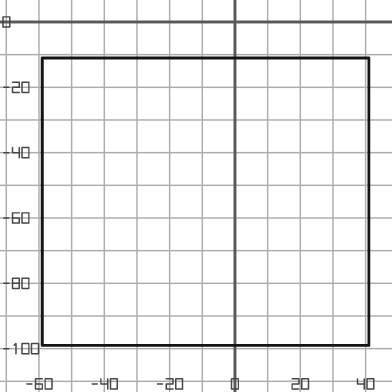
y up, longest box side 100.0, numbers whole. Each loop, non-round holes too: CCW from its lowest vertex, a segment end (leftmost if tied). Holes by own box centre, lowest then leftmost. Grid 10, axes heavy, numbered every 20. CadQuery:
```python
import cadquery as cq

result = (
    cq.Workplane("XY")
    .moveTo(-59.0, -99.0)
    .lineTo(41.0, -99.0)
    .lineTo(41.0, -11.0)
    .lineTo(-59.0, -11.0)
    .close()
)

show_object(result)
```